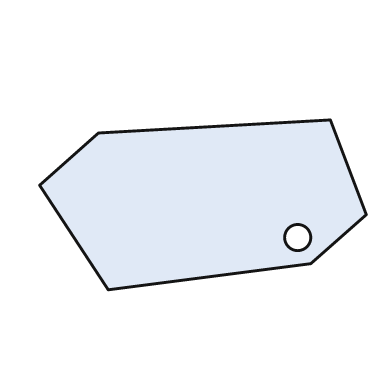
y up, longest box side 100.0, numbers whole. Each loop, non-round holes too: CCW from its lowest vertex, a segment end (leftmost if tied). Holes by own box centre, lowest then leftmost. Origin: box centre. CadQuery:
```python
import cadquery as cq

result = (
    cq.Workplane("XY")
    .moveTo(-29.0, -26.0)
    .lineTo(33.0, -18.0)
    .lineTo(50.0, -3.0)
    .lineTo(39.0, 26.0)
    .lineTo(-32.0, 22.0)
    .lineTo(-50.0, 6.0)
    .close()
    .moveTo(29.0, -10.0)
    .circle(4.0)
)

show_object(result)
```